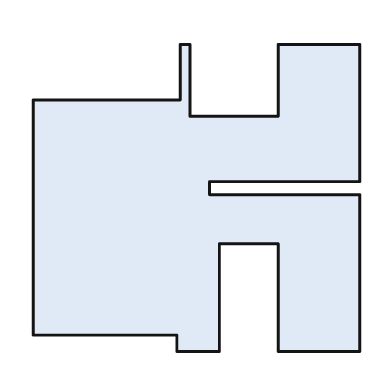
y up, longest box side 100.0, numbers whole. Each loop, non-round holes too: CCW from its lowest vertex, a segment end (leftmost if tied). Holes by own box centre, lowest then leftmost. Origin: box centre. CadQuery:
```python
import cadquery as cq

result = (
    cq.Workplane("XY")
    .moveTo(-6.0, -47.0)
    .lineTo(7.0, -47.0)
    .lineTo(7.0, -14.0)
    .lineTo(25.0, -14.0)
    .lineTo(25.0, -47.0)
    .lineTo(50.0, -47.0)
    .lineTo(50.0, 1.0)
    .lineTo(4.0, 1.0)
    .lineTo(4.0, 5.0)
    .lineTo(50.0, 5.0)
    .lineTo(50.0, 47.0)
    .lineTo(25.0, 47.0)
    .lineTo(25.0, 25.0)
    .lineTo(-2.0, 25.0)
    .lineTo(-2.0, 47.0)
    .lineTo(-5.0, 47.0)
    .lineTo(-5.0, 30.0)
    .lineTo(-50.0, 30.0)
    .lineTo(-50.0, -42.0)
    .lineTo(-6.0, -42.0)
    .close()
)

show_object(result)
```